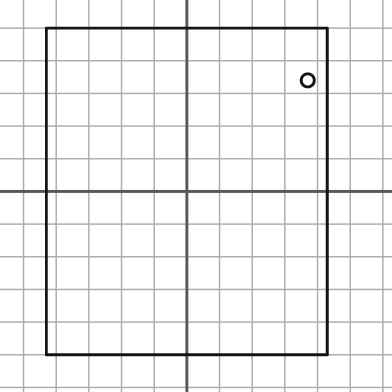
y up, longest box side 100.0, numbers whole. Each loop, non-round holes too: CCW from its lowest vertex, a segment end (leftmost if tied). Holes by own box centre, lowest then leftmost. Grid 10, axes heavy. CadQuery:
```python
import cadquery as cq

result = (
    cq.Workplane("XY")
    .moveTo(-43.0, -50.0)
    .lineTo(43.0, -50.0)
    .lineTo(43.0, 50.0)
    .lineTo(-43.0, 50.0)
    .close()
    .moveTo(37.0, 34.0)
    .circle(2.0)
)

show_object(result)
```